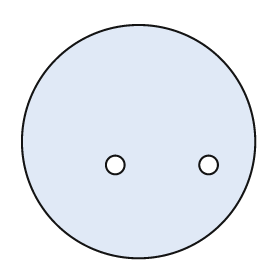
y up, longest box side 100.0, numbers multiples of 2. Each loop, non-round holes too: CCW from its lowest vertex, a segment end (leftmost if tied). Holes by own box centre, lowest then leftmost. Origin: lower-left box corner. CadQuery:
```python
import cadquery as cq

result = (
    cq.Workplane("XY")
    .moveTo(50.0, 50.0)
    .circle(50.0)
    .moveTo(40.0, 40.0)
    .circle(4.0)
    .moveTo(80.0, 40.0)
    .circle(4.0)
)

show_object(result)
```